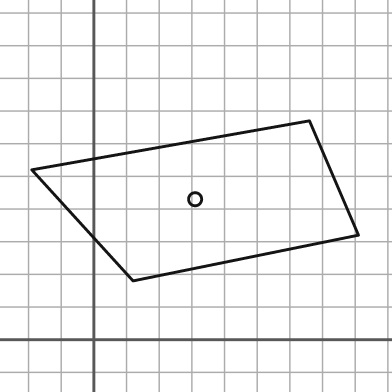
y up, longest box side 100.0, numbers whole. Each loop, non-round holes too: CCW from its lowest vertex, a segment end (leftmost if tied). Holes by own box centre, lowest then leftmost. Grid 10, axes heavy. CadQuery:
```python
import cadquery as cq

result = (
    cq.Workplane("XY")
    .moveTo(12.0, 18.0)
    .lineTo(81.0, 32.0)
    .lineTo(66.0, 67.0)
    .lineTo(-19.0, 52.0)
    .close()
    .moveTo(31.0, 43.0)
    .circle(2.0)
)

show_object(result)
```